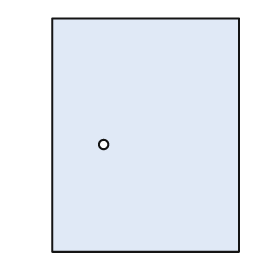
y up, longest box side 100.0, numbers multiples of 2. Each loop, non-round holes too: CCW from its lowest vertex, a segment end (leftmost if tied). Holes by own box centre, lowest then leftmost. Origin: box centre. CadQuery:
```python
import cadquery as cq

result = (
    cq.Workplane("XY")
    .moveTo(-40.0, -50.0)
    .lineTo(40.0, -50.0)
    .lineTo(40.0, 50.0)
    .lineTo(-40.0, 50.0)
    .close()
    .moveTo(-18.0, -4.0)
    .circle(2.0)
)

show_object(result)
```